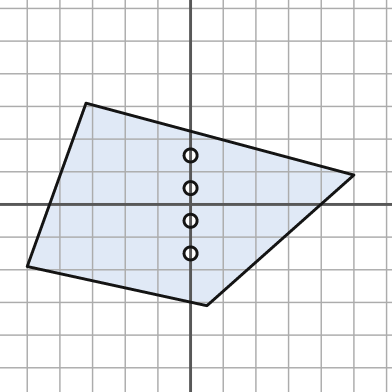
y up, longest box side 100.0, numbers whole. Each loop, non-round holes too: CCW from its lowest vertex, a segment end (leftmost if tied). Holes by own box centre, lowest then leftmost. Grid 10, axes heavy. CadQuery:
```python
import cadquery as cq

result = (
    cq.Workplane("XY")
    .moveTo(5.0, -31.0)
    .lineTo(50.0, 9.0)
    .lineTo(-32.0, 31.0)
    .lineTo(-50.0, -19.0)
    .close()
    .moveTo(0.0, -15.0)
    .circle(2.0)
    .moveTo(0.0, -5.0)
    .circle(2.0)
    .moveTo(0.0, 5.0)
    .circle(2.0)
    .moveTo(0.0, 15.0)
    .circle(2.0)
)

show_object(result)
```